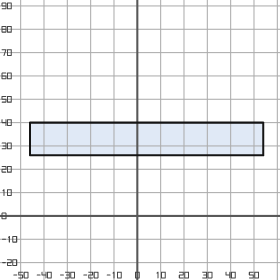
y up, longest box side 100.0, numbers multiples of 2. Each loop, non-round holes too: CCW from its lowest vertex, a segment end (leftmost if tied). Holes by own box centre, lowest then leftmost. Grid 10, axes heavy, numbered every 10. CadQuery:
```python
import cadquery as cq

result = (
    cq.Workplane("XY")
    .moveTo(-46.0, 26.0)
    .lineTo(54.0, 26.0)
    .lineTo(54.0, 40.0)
    .lineTo(-46.0, 40.0)
    .close()
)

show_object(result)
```